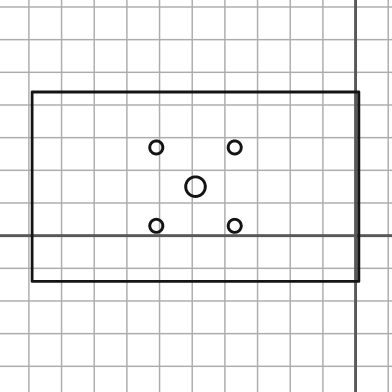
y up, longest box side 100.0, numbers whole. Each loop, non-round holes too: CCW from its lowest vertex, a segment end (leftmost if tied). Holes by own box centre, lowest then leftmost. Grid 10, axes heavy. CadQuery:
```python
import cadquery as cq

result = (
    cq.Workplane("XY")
    .moveTo(-99.0, -14.0)
    .lineTo(1.0, -14.0)
    .lineTo(1.0, 44.0)
    .lineTo(-99.0, 44.0)
    .close()
    .moveTo(-61.0, 3.0)
    .circle(2.0)
    .moveTo(-37.0, 3.0)
    .circle(2.0)
    .moveTo(-49.0, 15.0)
    .circle(3.0)
    .moveTo(-61.0, 27.0)
    .circle(2.0)
    .moveTo(-37.0, 27.0)
    .circle(2.0)
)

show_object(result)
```